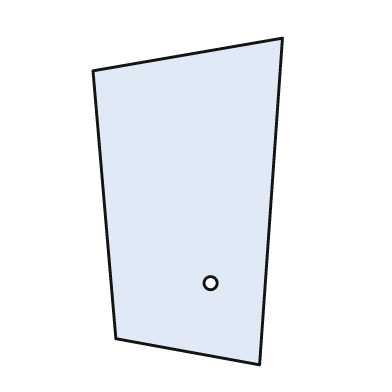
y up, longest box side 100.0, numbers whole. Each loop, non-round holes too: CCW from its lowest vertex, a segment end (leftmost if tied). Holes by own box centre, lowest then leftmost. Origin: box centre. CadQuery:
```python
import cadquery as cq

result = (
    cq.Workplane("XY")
    .moveTo(22.0, -50.0)
    .lineTo(29.0, 50.0)
    .lineTo(-29.0, 40.0)
    .lineTo(-22.0, -42.0)
    .close()
    .moveTo(7.0, -25.0)
    .circle(2.0)
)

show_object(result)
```